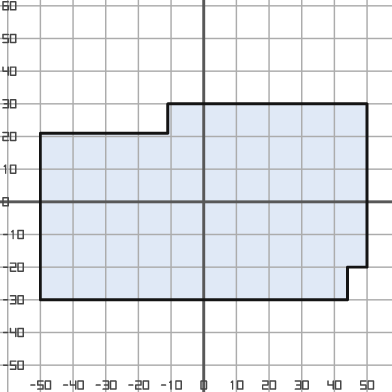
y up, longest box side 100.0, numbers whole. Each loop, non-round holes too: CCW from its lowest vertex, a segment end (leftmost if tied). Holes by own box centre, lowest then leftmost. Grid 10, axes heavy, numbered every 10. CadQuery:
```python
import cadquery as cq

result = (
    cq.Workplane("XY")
    .moveTo(-50.0, -30.0)
    .lineTo(44.0, -30.0)
    .lineTo(44.0, -20.0)
    .lineTo(50.0, -20.0)
    .lineTo(50.0, 30.0)
    .lineTo(-11.0, 30.0)
    .lineTo(-11.0, 21.0)
    .lineTo(-50.0, 21.0)
    .close()
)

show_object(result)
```